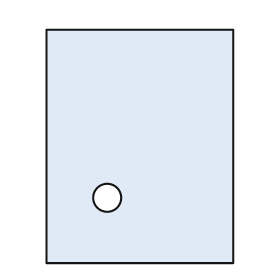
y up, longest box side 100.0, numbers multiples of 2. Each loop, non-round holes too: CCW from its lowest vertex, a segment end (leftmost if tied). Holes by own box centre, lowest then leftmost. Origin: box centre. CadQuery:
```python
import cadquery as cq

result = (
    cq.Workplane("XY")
    .moveTo(-40.0, -50.0)
    .lineTo(40.0, -50.0)
    .lineTo(40.0, 50.0)
    .lineTo(-40.0, 50.0)
    .close()
    .moveTo(-14.0, -22.0)
    .circle(6.0)
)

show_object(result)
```